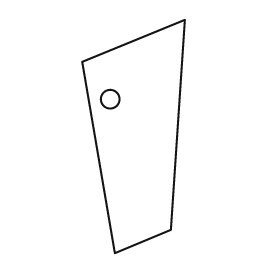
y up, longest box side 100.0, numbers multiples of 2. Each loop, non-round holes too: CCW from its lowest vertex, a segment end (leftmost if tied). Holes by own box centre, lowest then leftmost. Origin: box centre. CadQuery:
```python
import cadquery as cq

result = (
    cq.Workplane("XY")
    .moveTo(-8.0, -50.0)
    .lineTo(16.0, -40.0)
    .lineTo(22.0, 50.0)
    .lineTo(-22.0, 32.0)
    .close()
    .moveTo(-10.0, 16.0)
    .circle(4.0)
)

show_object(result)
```